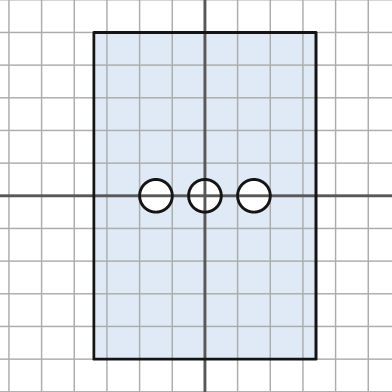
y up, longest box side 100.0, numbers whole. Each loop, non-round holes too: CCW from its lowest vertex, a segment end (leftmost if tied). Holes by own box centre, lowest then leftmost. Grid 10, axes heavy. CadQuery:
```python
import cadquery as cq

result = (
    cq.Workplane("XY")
    .moveTo(-34.0, -50.0)
    .lineTo(34.0, -50.0)
    .lineTo(34.0, 50.0)
    .lineTo(-34.0, 50.0)
    .close()
    .moveTo(-15.0, 0.0)
    .circle(5.0)
    .moveTo(0.0, 0.0)
    .circle(5.0)
    .moveTo(15.0, 0.0)
    .circle(5.0)
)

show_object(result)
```